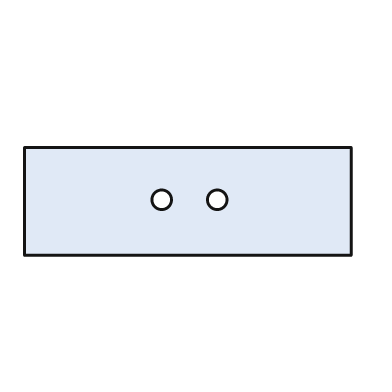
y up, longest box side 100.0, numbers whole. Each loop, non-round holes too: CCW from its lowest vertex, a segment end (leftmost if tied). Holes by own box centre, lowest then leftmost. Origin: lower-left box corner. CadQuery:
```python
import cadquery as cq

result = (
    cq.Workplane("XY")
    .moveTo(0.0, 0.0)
    .lineTo(100.0, 0.0)
    .lineTo(100.0, 33.0)
    .lineTo(0.0, 33.0)
    .close()
    .moveTo(42.0, 17.0)
    .circle(3.0)
    .moveTo(59.0, 17.0)
    .circle(3.0)
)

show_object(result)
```